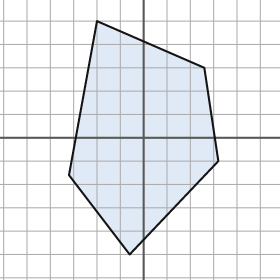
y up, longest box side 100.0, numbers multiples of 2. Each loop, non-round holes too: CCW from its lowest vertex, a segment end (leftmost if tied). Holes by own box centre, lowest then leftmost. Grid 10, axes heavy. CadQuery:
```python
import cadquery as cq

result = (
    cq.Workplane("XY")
    .moveTo(-6.0, -50.0)
    .lineTo(32.0, -10.0)
    .lineTo(26.0, 30.0)
    .lineTo(-20.0, 50.0)
    .lineTo(-32.0, -16.0)
    .close()
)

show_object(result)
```